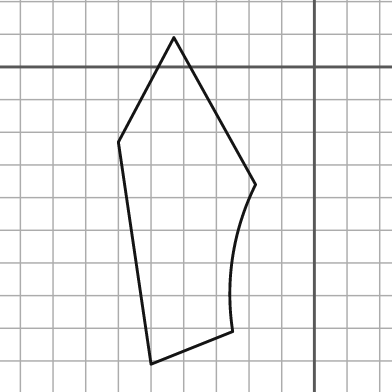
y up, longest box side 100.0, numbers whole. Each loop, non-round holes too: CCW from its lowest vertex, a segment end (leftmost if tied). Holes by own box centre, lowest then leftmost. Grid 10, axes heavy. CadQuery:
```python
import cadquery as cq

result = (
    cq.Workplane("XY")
    .moveTo(-50.0, -91.0)
    .lineTo(-25.0, -81.0)
    .threePointArc((-25.0, -58.0), (-18.0, -36.0))
    .lineTo(-43.0, 9.0)
    .lineTo(-60.0, -23.0)
    .close()
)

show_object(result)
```